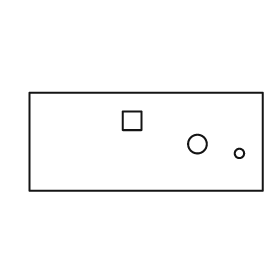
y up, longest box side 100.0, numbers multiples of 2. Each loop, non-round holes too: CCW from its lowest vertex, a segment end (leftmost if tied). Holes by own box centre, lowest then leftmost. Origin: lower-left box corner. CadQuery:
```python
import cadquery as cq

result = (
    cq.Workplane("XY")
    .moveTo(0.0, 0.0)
    .lineTo(100.0, 0.0)
    .lineTo(100.0, 42.0)
    .lineTo(0.0, 42.0)
    .close()
    .moveTo(90.0, 16.0)
    .circle(2.0)
    .moveTo(72.0, 20.0)
    .circle(4.0)
    .moveTo(40.0, 26.0)
    .lineTo(48.0, 26.0)
    .lineTo(48.0, 34.0)
    .lineTo(40.0, 34.0)
    .close()
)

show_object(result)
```